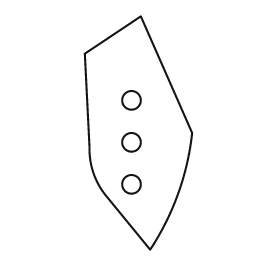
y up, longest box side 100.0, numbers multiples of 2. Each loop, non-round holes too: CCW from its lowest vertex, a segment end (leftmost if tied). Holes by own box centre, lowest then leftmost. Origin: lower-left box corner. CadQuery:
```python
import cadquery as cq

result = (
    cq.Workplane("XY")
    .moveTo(28.0, 0.0)
    .threePointArc((40.0, 24.0), (46.0, 50.0))
    .lineTo(24.0, 100.0)
    .lineTo(0.0, 84.0)
    .lineTo(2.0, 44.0)
    .threePointArc((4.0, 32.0), (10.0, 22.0))
    .close()
    .moveTo(20.0, 28.0)
    .circle(4.0)
    .moveTo(20.0, 46.0)
    .circle(4.0)
    .moveTo(20.0, 64.0)
    .circle(4.0)
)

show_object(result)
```